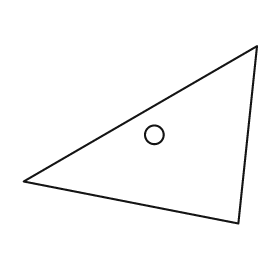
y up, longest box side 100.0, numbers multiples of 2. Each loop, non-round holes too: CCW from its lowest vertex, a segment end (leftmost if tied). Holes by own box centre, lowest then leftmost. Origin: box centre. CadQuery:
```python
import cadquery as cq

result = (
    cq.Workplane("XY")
    .moveTo(42.0, -38.0)
    .lineTo(50.0, 38.0)
    .lineTo(-50.0, -20.0)
    .close()
    .moveTo(6.0, 0.0)
    .circle(4.0)
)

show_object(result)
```